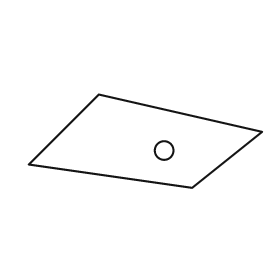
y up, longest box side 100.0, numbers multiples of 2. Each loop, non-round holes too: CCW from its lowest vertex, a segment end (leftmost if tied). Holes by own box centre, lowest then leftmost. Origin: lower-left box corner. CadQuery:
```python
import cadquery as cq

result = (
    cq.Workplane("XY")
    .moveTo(70.0, 0.0)
    .lineTo(100.0, 24.0)
    .lineTo(30.0, 40.0)
    .lineTo(0.0, 10.0)
    .close()
    .moveTo(58.0, 16.0)
    .circle(4.0)
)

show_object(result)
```